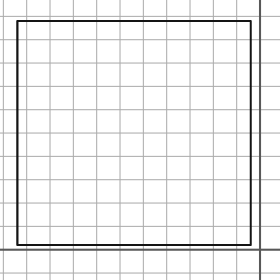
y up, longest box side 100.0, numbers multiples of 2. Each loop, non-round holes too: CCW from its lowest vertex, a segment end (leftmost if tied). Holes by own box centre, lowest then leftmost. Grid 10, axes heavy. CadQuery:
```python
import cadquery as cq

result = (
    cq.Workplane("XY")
    .moveTo(-104.0, 2.0)
    .lineTo(-4.0, 2.0)
    .lineTo(-4.0, 98.0)
    .lineTo(-104.0, 98.0)
    .close()
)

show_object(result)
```